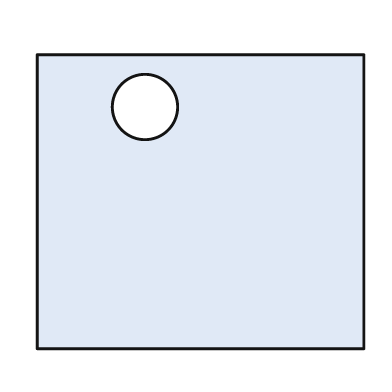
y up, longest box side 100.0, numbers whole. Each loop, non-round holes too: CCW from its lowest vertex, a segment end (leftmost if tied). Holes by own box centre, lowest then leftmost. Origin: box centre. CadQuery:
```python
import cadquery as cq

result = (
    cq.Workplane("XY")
    .moveTo(-50.0, -45.0)
    .lineTo(50.0, -45.0)
    .lineTo(50.0, 45.0)
    .lineTo(-50.0, 45.0)
    .close()
    .moveTo(-17.0, 29.0)
    .circle(10.0)
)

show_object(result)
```